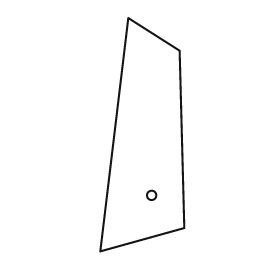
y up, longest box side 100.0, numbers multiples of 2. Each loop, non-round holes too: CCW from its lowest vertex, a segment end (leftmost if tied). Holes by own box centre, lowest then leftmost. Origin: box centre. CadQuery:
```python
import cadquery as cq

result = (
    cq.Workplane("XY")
    .moveTo(-18.0, -50.0)
    .lineTo(18.0, -40.0)
    .lineTo(16.0, 36.0)
    .lineTo(-6.0, 50.0)
    .close()
    .moveTo(4.0, -26.0)
    .circle(2.0)
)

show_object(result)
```